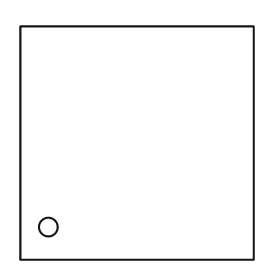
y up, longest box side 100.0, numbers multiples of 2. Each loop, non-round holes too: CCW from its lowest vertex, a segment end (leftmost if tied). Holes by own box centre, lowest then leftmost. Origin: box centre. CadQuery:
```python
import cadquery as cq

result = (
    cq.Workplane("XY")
    .moveTo(-50.0, -50.0)
    .lineTo(50.0, -50.0)
    .lineTo(50.0, 50.0)
    .lineTo(-50.0, 50.0)
    .close()
    .moveTo(-38.0, -36.0)
    .circle(4.0)
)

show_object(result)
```